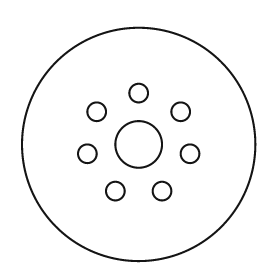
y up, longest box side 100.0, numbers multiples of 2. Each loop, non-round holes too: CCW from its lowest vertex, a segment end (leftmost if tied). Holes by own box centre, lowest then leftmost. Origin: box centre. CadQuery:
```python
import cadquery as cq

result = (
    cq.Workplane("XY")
    .moveTo(0.0, 0.0)
    .circle(50.0)
    .moveTo(-10.0, -20.0)
    .circle(4.0)
    .moveTo(10.0, -20.0)
    .circle(4.0)
    .moveTo(-22.0, -4.0)
    .circle(4.0)
    .moveTo(22.0, -4.0)
    .circle(4.0)
    .moveTo(0.0, 0.0)
    .circle(10.0)
    .moveTo(-18.0, 14.0)
    .circle(4.0)
    .moveTo(18.0, 14.0)
    .circle(4.0)
    .moveTo(0.0, 22.0)
    .circle(4.0)
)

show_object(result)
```